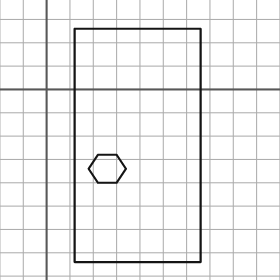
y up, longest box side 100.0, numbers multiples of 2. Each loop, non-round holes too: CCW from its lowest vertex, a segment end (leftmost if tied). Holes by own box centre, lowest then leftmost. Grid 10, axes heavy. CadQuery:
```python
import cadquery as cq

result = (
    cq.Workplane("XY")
    .moveTo(12.0, -74.0)
    .lineTo(66.0, -74.0)
    .lineTo(66.0, 26.0)
    .lineTo(12.0, 26.0)
    .close()
    .moveTo(22.0, -40.0)
    .lineTo(30.0, -40.0)
    .lineTo(34.0, -34.0)
    .lineTo(30.0, -28.0)
    .lineTo(22.0, -28.0)
    .lineTo(18.0, -34.0)
    .close()
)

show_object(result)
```